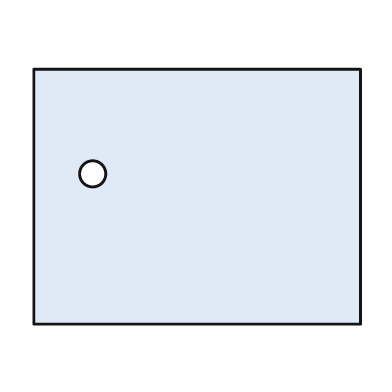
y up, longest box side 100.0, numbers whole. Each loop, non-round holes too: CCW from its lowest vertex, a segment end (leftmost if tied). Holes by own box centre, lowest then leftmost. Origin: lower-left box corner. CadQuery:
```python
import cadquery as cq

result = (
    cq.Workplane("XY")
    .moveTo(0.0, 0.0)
    .lineTo(100.0, 0.0)
    .lineTo(100.0, 78.0)
    .lineTo(0.0, 78.0)
    .close()
    .moveTo(18.0, 46.0)
    .circle(4.0)
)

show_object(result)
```